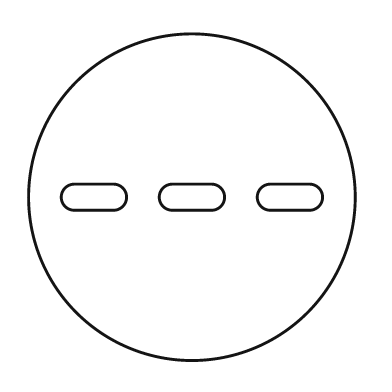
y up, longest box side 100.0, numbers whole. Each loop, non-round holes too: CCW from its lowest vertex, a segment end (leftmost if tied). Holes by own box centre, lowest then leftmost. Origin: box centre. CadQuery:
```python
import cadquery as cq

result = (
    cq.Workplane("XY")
    .moveTo(0.0, 0.0)
    .circle(50.0)
    .moveTo(-36.0, -4.0)
    .lineTo(-24.0, -4.0)
    .threePointArc((-20.0, 0.0), (-24.0, 4.0))
    .lineTo(-36.0, 4.0)
    .threePointArc((-40.0, 0.0), (-36.0, -4.0))
    .close()
    .moveTo(-6.0, -4.0)
    .lineTo(6.0, -4.0)
    .threePointArc((10.0, 0.0), (6.0, 4.0))
    .lineTo(-6.0, 4.0)
    .threePointArc((-10.0, 0.0), (-6.0, -4.0))
    .close()
    .moveTo(24.0, -4.0)
    .lineTo(36.0, -4.0)
    .threePointArc((40.0, 0.0), (36.0, 4.0))
    .lineTo(24.0, 4.0)
    .threePointArc((20.0, 0.0), (24.0, -4.0))
    .close()
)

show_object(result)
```